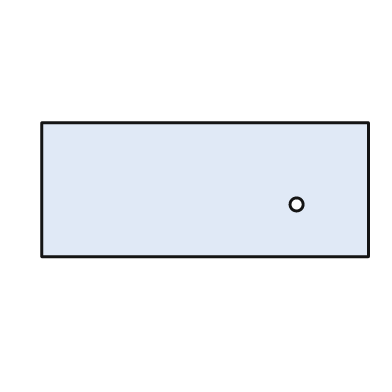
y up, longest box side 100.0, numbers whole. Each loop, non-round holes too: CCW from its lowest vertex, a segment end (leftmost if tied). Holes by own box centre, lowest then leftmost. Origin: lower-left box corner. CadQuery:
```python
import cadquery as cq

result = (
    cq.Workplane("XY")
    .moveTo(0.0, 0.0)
    .lineTo(100.0, 0.0)
    .lineTo(100.0, 41.0)
    .lineTo(0.0, 41.0)
    .close()
    .moveTo(78.0, 16.0)
    .circle(2.0)
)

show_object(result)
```